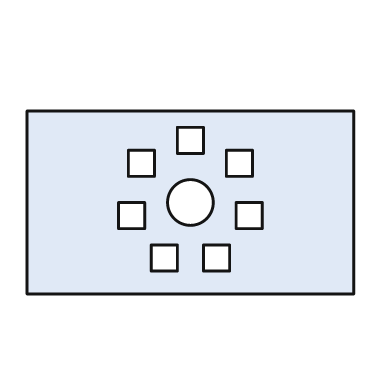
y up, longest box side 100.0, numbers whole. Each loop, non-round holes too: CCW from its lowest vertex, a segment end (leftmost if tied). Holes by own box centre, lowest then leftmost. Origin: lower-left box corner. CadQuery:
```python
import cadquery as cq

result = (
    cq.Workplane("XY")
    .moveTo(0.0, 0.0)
    .lineTo(100.0, 0.0)
    .lineTo(100.0, 56.0)
    .lineTo(0.0, 56.0)
    .close()
    .moveTo(38.0, 7.0)
    .lineTo(46.0, 7.0)
    .lineTo(46.0, 15.0)
    .lineTo(38.0, 15.0)
    .close()
    .moveTo(54.0, 7.0)
    .lineTo(62.0, 7.0)
    .lineTo(62.0, 15.0)
    .lineTo(54.0, 15.0)
    .close()
    .moveTo(28.0, 20.0)
    .lineTo(36.0, 20.0)
    .lineTo(36.0, 28.0)
    .lineTo(28.0, 28.0)
    .close()
    .moveTo(64.0, 20.0)
    .lineTo(72.0, 20.0)
    .lineTo(72.0, 28.0)
    .lineTo(64.0, 28.0)
    .close()
    .moveTo(50.0, 28.0)
    .circle(7.0)
    .moveTo(31.0, 36.0)
    .lineTo(39.0, 36.0)
    .lineTo(39.0, 44.0)
    .lineTo(31.0, 44.0)
    .close()
    .moveTo(61.0, 36.0)
    .lineTo(69.0, 36.0)
    .lineTo(69.0, 44.0)
    .lineTo(61.0, 44.0)
    .close()
    .moveTo(46.0, 43.0)
    .lineTo(54.0, 43.0)
    .lineTo(54.0, 51.0)
    .lineTo(46.0, 51.0)
    .close()
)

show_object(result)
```